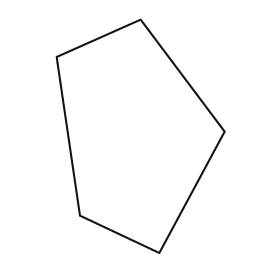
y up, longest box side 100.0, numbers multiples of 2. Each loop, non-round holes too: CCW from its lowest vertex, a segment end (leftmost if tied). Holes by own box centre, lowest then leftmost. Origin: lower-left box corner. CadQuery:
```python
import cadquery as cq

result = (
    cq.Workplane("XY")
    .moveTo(44.0, 0.0)
    .lineTo(72.0, 52.0)
    .lineTo(36.0, 100.0)
    .lineTo(0.0, 84.0)
    .lineTo(10.0, 16.0)
    .close()
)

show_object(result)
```